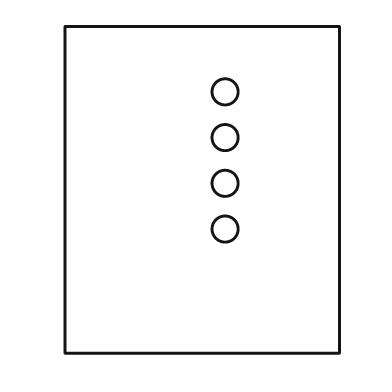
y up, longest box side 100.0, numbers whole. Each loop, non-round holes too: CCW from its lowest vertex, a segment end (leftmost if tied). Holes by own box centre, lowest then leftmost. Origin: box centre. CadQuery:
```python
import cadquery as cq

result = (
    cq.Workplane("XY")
    .moveTo(-42.0, -50.0)
    .lineTo(42.0, -50.0)
    .lineTo(42.0, 50.0)
    .lineTo(-42.0, 50.0)
    .close()
    .moveTo(7.0, -12.0)
    .circle(4.0)
    .moveTo(7.0, 2.0)
    .circle(4.0)
    .moveTo(7.0, 16.0)
    .circle(4.0)
    .moveTo(7.0, 30.0)
    .circle(4.0)
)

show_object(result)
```